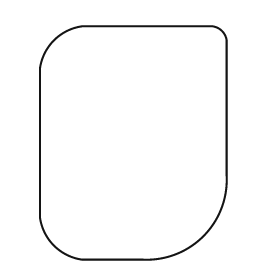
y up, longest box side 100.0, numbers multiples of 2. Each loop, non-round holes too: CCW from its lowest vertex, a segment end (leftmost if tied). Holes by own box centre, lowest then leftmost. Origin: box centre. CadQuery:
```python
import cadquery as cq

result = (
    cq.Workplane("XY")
    .moveTo(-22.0, -50.0)
    .lineTo(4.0, -50.0)
    .threePointArc((30.0, -40.0), (40.0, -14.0))
    .lineTo(40.0, 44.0)
    .threePointArc((38.0, 48.0), (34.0, 50.0))
    .lineTo(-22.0, 50.0)
    .threePointArc((-34.0, 44.0), (-40.0, 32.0))
    .lineTo(-40.0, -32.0)
    .threePointArc((-34.0, -44.0), (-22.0, -50.0))
    .close()
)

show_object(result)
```